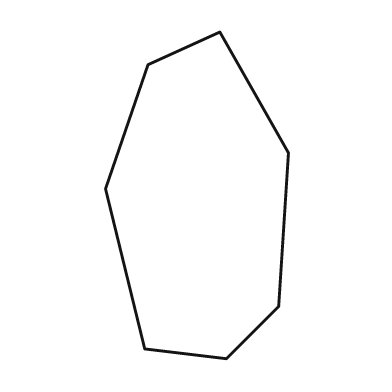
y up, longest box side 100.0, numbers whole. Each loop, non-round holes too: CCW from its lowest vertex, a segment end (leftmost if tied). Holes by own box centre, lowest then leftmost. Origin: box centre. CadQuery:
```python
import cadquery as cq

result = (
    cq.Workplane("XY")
    .moveTo(9.0, -50.0)
    .lineTo(25.0, -34.0)
    .lineTo(28.0, 13.0)
    .lineTo(7.0, 50.0)
    .lineTo(-15.0, 40.0)
    .lineTo(-28.0, 2.0)
    .lineTo(-16.0, -47.0)
    .close()
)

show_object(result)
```